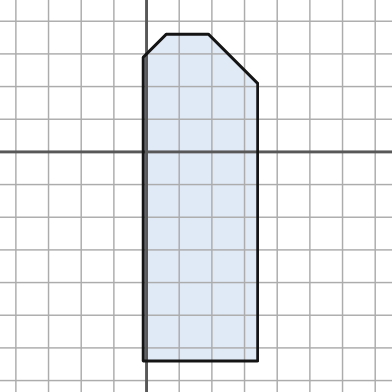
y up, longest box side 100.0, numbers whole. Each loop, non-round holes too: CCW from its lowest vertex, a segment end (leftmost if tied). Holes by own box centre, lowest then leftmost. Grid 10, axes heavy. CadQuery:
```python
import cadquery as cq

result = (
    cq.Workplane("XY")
    .moveTo(-1.0, -64.0)
    .lineTo(34.0, -64.0)
    .lineTo(34.0, 21.0)
    .lineTo(19.0, 36.0)
    .lineTo(6.0, 36.0)
    .lineTo(-1.0, 29.0)
    .close()
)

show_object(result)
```